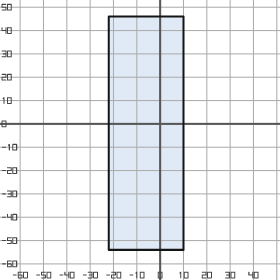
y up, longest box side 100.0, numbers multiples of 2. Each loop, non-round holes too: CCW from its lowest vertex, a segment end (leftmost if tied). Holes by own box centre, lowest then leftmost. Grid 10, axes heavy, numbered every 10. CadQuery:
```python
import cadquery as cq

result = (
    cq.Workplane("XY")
    .moveTo(-22.0, -54.0)
    .lineTo(10.0, -54.0)
    .lineTo(10.0, 46.0)
    .lineTo(-22.0, 46.0)
    .close()
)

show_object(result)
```